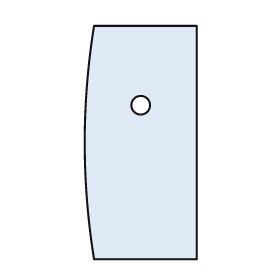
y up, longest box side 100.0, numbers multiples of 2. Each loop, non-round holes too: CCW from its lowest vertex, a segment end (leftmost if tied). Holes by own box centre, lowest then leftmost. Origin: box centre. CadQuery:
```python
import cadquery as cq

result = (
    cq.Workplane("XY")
    .moveTo(-20.0, -50.0)
    .lineTo(24.0, -50.0)
    .lineTo(24.0, 50.0)
    .lineTo(-20.0, 50.0)
    .threePointArc((-24.0, 0.0), (-20.0, -50.0))
    .close()
    .moveTo(0.0, 16.0)
    .circle(4.0)
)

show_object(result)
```